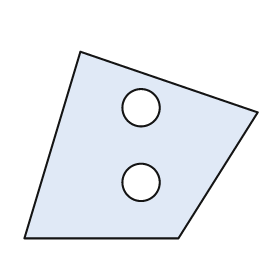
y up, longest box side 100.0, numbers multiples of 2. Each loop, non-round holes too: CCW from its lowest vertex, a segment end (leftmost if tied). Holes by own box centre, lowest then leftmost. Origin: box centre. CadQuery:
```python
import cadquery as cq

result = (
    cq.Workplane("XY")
    .moveTo(-50.0, -40.0)
    .lineTo(16.0, -40.0)
    .lineTo(50.0, 14.0)
    .lineTo(-26.0, 40.0)
    .close()
    .moveTo(0.0, -16.0)
    .circle(8.0)
    .moveTo(0.0, 16.0)
    .circle(8.0)
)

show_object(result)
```